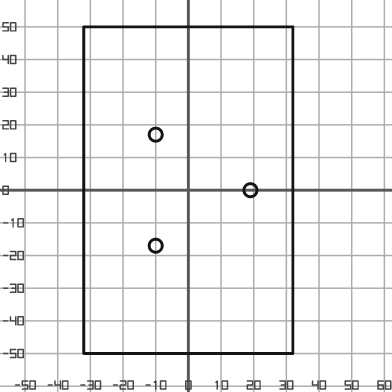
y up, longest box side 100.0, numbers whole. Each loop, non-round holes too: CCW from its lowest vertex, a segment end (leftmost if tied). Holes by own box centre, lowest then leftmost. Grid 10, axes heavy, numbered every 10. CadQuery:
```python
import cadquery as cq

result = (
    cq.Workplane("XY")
    .moveTo(-32.0, -50.0)
    .lineTo(32.0, -50.0)
    .lineTo(32.0, 50.0)
    .lineTo(-32.0, 50.0)
    .close()
    .moveTo(-10.0, -17.0)
    .circle(2.0)
    .moveTo(19.0, 0.0)
    .circle(2.0)
    .moveTo(-10.0, 17.0)
    .circle(2.0)
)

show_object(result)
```